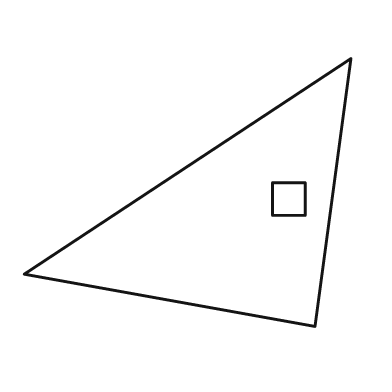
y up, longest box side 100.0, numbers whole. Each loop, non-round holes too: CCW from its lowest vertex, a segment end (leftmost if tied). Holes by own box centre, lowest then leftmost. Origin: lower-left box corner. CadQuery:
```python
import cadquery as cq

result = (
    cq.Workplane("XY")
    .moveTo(89.0, 0.0)
    .lineTo(100.0, 82.0)
    .lineTo(0.0, 16.0)
    .close()
    .moveTo(76.0, 34.0)
    .lineTo(86.0, 34.0)
    .lineTo(86.0, 44.0)
    .lineTo(76.0, 44.0)
    .close()
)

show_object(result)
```